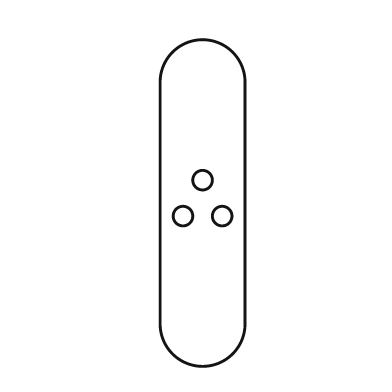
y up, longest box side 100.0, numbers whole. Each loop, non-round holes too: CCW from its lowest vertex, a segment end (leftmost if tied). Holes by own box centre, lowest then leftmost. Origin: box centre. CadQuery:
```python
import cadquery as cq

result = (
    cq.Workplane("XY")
    .moveTo(-13.0, -37.0)
    .threePointArc((0.0, -50.0), (13.0, -37.0))
    .lineTo(13.0, 37.0)
    .threePointArc((0.0, 50.0), (-13.0, 37.0))
    .close()
    .moveTo(-6.0, -4.0)
    .circle(3.0)
    .moveTo(6.0, -4.0)
    .circle(3.0)
    .moveTo(0.0, 7.0)
    .circle(3.0)
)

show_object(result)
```